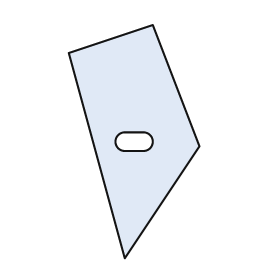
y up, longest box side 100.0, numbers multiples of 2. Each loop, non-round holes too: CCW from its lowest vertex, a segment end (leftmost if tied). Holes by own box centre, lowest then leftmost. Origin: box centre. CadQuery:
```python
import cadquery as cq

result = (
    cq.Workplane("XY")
    .moveTo(-4.0, -50.0)
    .lineTo(28.0, -2.0)
    .lineTo(8.0, 50.0)
    .lineTo(-28.0, 38.0)
    .close()
    .moveTo(-4.0, -4.0)
    .lineTo(4.0, -4.0)
    .threePointArc((8.0, 0.0), (4.0, 4.0))
    .lineTo(-4.0, 4.0)
    .threePointArc((-8.0, 0.0), (-4.0, -4.0))
    .close()
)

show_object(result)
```